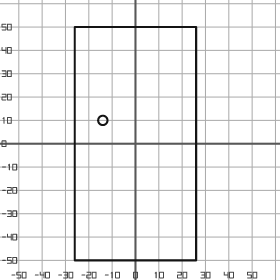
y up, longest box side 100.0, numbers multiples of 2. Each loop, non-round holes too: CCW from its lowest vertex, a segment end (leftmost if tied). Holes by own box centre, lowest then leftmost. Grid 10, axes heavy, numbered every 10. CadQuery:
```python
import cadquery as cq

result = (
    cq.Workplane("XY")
    .moveTo(-26.0, -50.0)
    .lineTo(26.0, -50.0)
    .lineTo(26.0, 50.0)
    .lineTo(-26.0, 50.0)
    .close()
    .moveTo(-14.0, 10.0)
    .circle(2.0)
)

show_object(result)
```